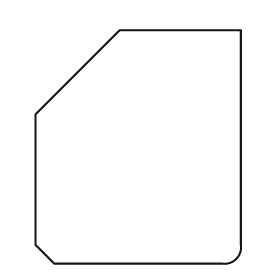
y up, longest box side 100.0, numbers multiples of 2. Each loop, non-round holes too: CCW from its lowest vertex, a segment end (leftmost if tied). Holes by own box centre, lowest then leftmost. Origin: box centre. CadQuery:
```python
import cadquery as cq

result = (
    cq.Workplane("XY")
    .moveTo(-36.0, -50.0)
    .lineTo(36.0, -50.0)
    .threePointArc((42.0, -48.0), (44.0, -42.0))
    .lineTo(44.0, 50.0)
    .lineTo(-8.0, 50.0)
    .lineTo(-44.0, 14.0)
    .lineTo(-44.0, -42.0)
    .close()
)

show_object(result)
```